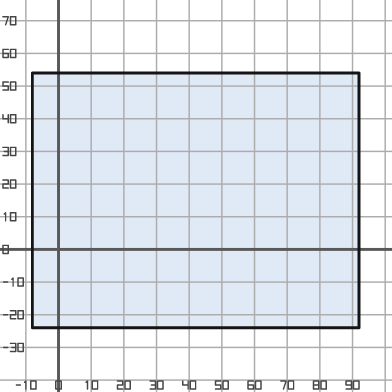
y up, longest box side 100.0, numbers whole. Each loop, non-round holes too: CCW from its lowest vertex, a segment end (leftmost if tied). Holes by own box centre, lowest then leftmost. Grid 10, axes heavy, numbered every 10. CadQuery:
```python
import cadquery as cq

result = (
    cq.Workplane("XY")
    .moveTo(-8.0, -24.0)
    .lineTo(92.0, -24.0)
    .lineTo(92.0, 54.0)
    .lineTo(-8.0, 54.0)
    .close()
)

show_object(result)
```